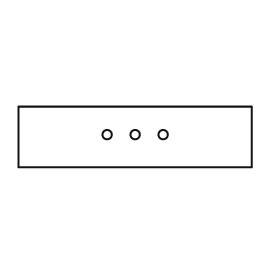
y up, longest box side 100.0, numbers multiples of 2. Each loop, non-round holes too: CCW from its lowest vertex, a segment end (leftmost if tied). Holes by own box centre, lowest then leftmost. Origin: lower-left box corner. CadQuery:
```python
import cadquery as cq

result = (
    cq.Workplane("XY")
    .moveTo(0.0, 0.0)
    .lineTo(100.0, 0.0)
    .lineTo(100.0, 26.0)
    .lineTo(0.0, 26.0)
    .close()
    .moveTo(38.0, 14.0)
    .circle(2.0)
    .moveTo(50.0, 14.0)
    .circle(2.0)
    .moveTo(62.0, 14.0)
    .circle(2.0)
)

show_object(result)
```